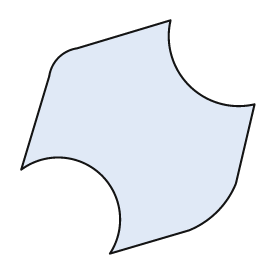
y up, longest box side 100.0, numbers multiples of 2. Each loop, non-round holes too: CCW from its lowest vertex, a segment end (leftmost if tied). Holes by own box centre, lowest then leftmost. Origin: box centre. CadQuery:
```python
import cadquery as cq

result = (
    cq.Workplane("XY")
    .moveTo(-12.0, -50.0)
    .lineTo(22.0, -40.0)
    .threePointArc((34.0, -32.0), (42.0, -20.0))
    .lineTo(50.0, 14.0)
    .threePointArc((22.0, 22.0), (14.0, 50.0))
    .lineTo(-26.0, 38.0)
    .threePointArc((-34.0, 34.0), (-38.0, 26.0))
    .lineTo(-50.0, -14.0)
    .threePointArc((-16.0, -16.0), (-12.0, -50.0))
    .close()
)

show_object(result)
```